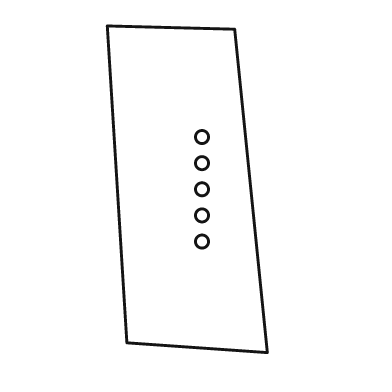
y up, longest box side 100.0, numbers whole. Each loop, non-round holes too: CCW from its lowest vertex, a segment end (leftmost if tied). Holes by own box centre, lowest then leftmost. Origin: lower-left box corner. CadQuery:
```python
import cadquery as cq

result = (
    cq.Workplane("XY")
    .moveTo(49.0, 0.0)
    .lineTo(39.0, 99.0)
    .lineTo(0.0, 100.0)
    .lineTo(6.0, 3.0)
    .close()
    .moveTo(29.0, 34.0)
    .circle(2.0)
    .moveTo(29.0, 42.0)
    .circle(2.0)
    .moveTo(29.0, 50.0)
    .circle(2.0)
    .moveTo(29.0, 58.0)
    .circle(2.0)
    .moveTo(29.0, 66.0)
    .circle(2.0)
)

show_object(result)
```